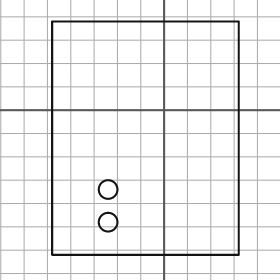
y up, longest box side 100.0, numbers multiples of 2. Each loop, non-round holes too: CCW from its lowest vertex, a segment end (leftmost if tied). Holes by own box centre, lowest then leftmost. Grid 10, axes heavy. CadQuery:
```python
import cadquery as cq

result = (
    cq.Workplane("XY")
    .moveTo(-48.0, -62.0)
    .lineTo(32.0, -62.0)
    .lineTo(32.0, 38.0)
    .lineTo(-48.0, 38.0)
    .close()
    .moveTo(-24.0, -48.0)
    .circle(4.0)
    .moveTo(-24.0, -34.0)
    .circle(4.0)
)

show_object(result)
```